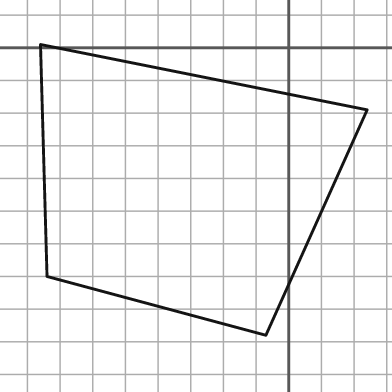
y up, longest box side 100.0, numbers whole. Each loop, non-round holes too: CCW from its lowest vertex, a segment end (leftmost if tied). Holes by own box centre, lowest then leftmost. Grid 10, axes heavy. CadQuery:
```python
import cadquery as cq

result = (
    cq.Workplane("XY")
    .moveTo(-7.0, -88.0)
    .lineTo(24.0, -19.0)
    .lineTo(-76.0, 1.0)
    .lineTo(-74.0, -70.0)
    .close()
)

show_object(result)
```